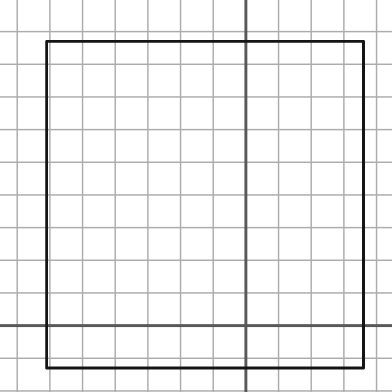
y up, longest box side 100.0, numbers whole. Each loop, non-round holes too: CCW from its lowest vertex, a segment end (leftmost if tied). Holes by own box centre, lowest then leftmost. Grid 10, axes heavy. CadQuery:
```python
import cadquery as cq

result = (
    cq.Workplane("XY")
    .moveTo(-61.0, -13.0)
    .lineTo(36.0, -13.0)
    .lineTo(36.0, 87.0)
    .lineTo(-61.0, 87.0)
    .close()
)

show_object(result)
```